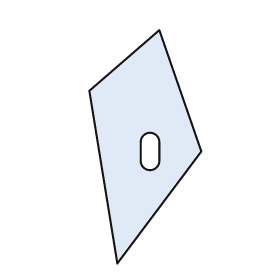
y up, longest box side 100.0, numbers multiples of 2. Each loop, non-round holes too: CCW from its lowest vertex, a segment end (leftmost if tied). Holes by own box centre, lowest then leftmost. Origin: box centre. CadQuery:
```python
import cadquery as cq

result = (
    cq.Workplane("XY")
    .moveTo(-12.0, -50.0)
    .lineTo(24.0, -2.0)
    .lineTo(6.0, 50.0)
    .lineTo(-24.0, 24.0)
    .close()
    .moveTo(-2.0, -6.0)
    .threePointArc((2.0, -10.0), (6.0, -6.0))
    .lineTo(6.0, 2.0)
    .threePointArc((2.0, 6.0), (-2.0, 2.0))
    .close()
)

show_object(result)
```